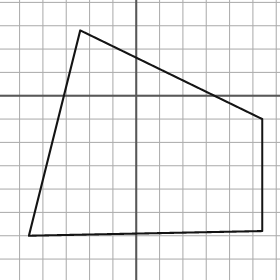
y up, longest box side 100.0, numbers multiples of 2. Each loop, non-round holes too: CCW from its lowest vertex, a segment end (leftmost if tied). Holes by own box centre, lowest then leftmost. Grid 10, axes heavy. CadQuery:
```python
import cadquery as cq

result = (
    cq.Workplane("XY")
    .moveTo(-46.0, -60.0)
    .lineTo(54.0, -58.0)
    .lineTo(54.0, -10.0)
    .lineTo(-24.0, 28.0)
    .close()
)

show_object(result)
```